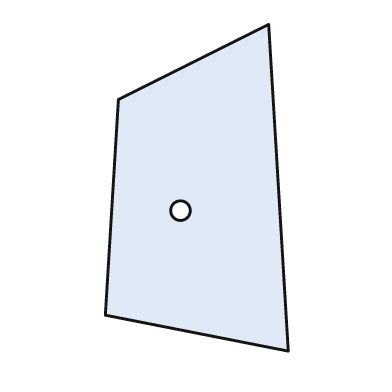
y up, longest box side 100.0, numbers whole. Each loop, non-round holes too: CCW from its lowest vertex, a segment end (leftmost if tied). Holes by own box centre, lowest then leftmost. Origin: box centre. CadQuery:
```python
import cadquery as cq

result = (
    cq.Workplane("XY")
    .moveTo(28.0, -50.0)
    .lineTo(22.0, 50.0)
    .lineTo(-24.0, 27.0)
    .lineTo(-28.0, -39.0)
    .close()
    .moveTo(-5.0, -7.0)
    .circle(3.0)
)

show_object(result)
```